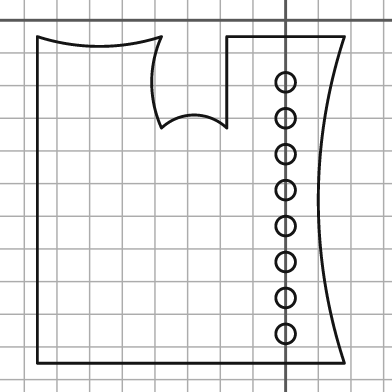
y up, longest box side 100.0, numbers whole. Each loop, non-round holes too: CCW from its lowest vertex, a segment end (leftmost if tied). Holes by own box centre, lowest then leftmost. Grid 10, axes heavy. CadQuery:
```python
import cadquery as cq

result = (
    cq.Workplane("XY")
    .moveTo(-76.0, -105.0)
    .lineTo(18.0, -105.0)
    .threePointArc((10.0, -55.0), (18.0, -5.0))
    .lineTo(-18.0, -5.0)
    .lineTo(-18.0, -33.0)
    .threePointArc((-28.0, -29.0), (-38.0, -33.0))
    .threePointArc((-41.0, -19.0), (-38.0, -5.0))
    .threePointArc((-57.0, -8.0), (-76.0, -5.0))
    .close()
    .moveTo(0.0, -96.0)
    .circle(3.0)
    .moveTo(0.0, -85.0)
    .circle(3.0)
    .moveTo(0.0, -74.0)
    .circle(3.0)
    .moveTo(0.0, -63.0)
    .circle(3.0)
    .moveTo(0.0, -52.0)
    .circle(3.0)
    .moveTo(0.0, -41.0)
    .circle(3.0)
    .moveTo(0.0, -30.0)
    .circle(3.0)
    .moveTo(0.0, -19.0)
    .circle(3.0)
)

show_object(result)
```